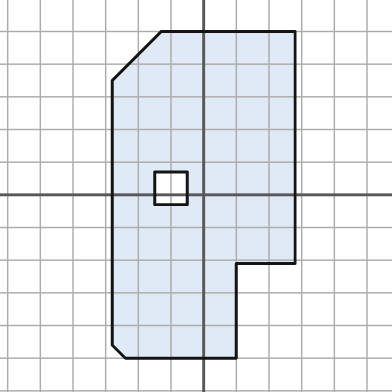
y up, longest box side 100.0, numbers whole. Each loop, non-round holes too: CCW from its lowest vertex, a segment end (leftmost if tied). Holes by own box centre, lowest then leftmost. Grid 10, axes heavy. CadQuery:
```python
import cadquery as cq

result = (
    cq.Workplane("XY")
    .moveTo(-24.0, -50.0)
    .lineTo(10.0, -50.0)
    .lineTo(10.0, -21.0)
    .lineTo(28.0, -21.0)
    .lineTo(28.0, 50.0)
    .lineTo(-13.0, 50.0)
    .lineTo(-28.0, 35.0)
    .lineTo(-28.0, -46.0)
    .close()
    .moveTo(-15.0, -3.0)
    .lineTo(-5.0, -3.0)
    .lineTo(-5.0, 7.0)
    .lineTo(-15.0, 7.0)
    .close()
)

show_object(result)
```